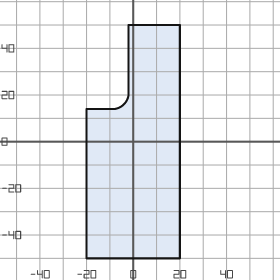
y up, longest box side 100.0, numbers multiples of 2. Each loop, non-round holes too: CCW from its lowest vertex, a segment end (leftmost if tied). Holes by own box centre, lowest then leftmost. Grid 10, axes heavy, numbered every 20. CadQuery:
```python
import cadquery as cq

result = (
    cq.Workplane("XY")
    .moveTo(-20.0, -50.0)
    .lineTo(20.0, -50.0)
    .lineTo(20.0, 50.0)
    .lineTo(-2.0, 50.0)
    .lineTo(-2.0, 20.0)
    .threePointArc((-4.0, 16.0), (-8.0, 14.0))
    .lineTo(-20.0, 14.0)
    .close()
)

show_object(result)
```